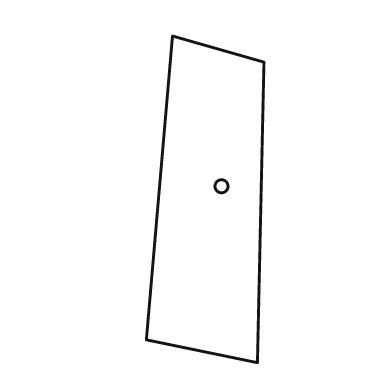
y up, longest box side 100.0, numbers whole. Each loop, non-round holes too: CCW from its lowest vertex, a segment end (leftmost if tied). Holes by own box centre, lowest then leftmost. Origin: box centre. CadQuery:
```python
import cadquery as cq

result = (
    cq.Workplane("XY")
    .moveTo(16.0, -50.0)
    .lineTo(18.0, 42.0)
    .lineTo(-10.0, 50.0)
    .lineTo(-18.0, -43.0)
    .close()
    .moveTo(5.0, 4.0)
    .circle(2.0)
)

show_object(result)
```